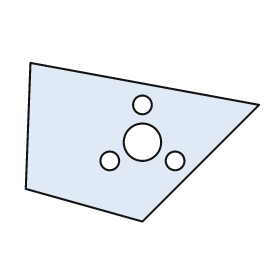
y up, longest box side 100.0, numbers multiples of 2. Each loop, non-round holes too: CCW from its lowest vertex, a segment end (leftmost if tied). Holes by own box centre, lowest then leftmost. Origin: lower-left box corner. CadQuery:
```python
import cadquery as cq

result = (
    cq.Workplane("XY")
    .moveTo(50.0, 0.0)
    .lineTo(100.0, 50.0)
    .lineTo(2.0, 68.0)
    .lineTo(0.0, 14.0)
    .close()
    .moveTo(36.0, 26.0)
    .circle(4.0)
    .moveTo(64.0, 26.0)
    .circle(4.0)
    .moveTo(50.0, 34.0)
    .circle(8.0)
    .moveTo(50.0, 50.0)
    .circle(4.0)
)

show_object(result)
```